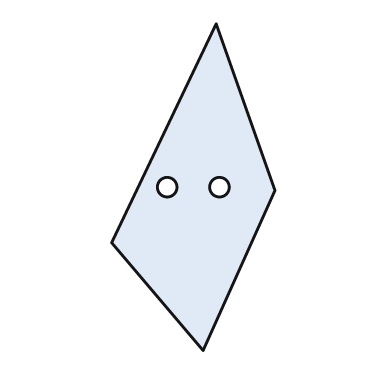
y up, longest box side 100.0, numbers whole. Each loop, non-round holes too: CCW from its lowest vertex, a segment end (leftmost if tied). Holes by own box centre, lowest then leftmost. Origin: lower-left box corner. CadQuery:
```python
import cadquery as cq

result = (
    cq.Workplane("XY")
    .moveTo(28.0, 0.0)
    .lineTo(50.0, 49.0)
    .lineTo(32.0, 100.0)
    .lineTo(0.0, 33.0)
    .close()
    .moveTo(17.0, 50.0)
    .circle(3.0)
    .moveTo(33.0, 50.0)
    .circle(3.0)
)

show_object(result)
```